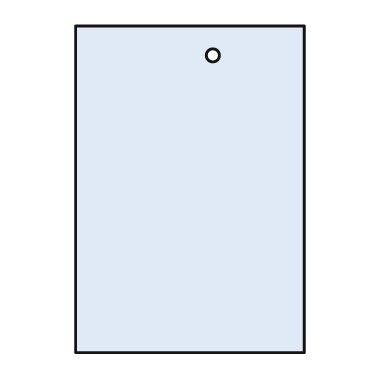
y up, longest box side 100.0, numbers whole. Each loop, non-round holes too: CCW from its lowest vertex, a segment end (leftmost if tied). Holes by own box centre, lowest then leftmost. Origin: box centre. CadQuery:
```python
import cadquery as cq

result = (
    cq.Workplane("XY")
    .moveTo(-35.0, -50.0)
    .lineTo(35.0, -50.0)
    .lineTo(35.0, 50.0)
    .lineTo(-35.0, 50.0)
    .close()
    .moveTo(7.0, 41.0)
    .circle(2.0)
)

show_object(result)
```